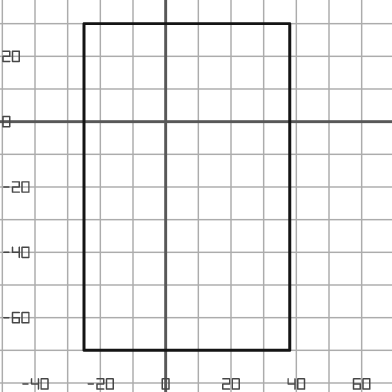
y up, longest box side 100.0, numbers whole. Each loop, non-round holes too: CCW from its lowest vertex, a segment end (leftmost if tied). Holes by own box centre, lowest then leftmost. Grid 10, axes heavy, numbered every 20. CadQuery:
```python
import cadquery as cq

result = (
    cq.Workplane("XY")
    .moveTo(-25.0, -70.0)
    .lineTo(38.0, -70.0)
    .lineTo(38.0, 30.0)
    .lineTo(-25.0, 30.0)
    .close()
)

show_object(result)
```